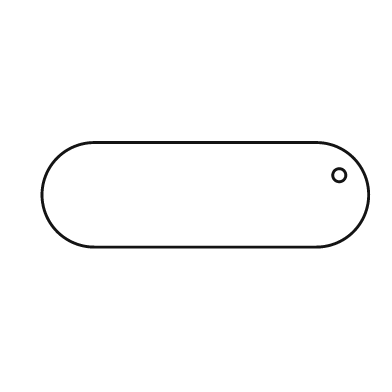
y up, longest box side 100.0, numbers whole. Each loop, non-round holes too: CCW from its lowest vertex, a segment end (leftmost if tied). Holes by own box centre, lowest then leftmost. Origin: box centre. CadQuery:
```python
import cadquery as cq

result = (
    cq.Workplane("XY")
    .moveTo(-34.0, -16.0)
    .lineTo(34.0, -16.0)
    .threePointArc((50.0, 0.0), (34.0, 16.0))
    .lineTo(-34.0, 16.0)
    .threePointArc((-50.0, 0.0), (-34.0, -16.0))
    .close()
    .moveTo(41.0, 6.0)
    .circle(2.0)
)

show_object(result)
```